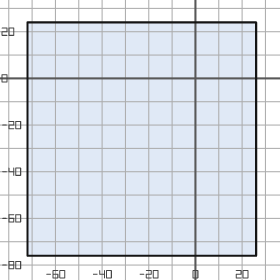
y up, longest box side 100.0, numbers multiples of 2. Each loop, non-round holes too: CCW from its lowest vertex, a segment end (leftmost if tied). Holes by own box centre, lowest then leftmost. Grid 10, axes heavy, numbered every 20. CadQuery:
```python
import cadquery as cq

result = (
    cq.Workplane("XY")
    .moveTo(-72.0, -76.0)
    .lineTo(26.0, -76.0)
    .lineTo(26.0, 24.0)
    .lineTo(-72.0, 24.0)
    .close()
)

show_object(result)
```